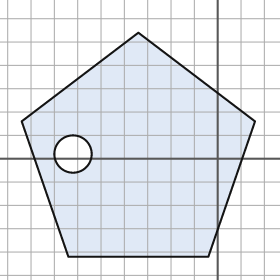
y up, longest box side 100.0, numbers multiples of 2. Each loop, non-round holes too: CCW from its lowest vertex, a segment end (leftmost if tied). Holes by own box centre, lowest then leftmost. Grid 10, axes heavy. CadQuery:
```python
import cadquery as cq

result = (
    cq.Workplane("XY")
    .moveTo(-64.0, -42.0)
    .lineTo(-4.0, -42.0)
    .lineTo(16.0, 16.0)
    .lineTo(-34.0, 54.0)
    .lineTo(-84.0, 16.0)
    .close()
    .moveTo(-62.0, 2.0)
    .circle(8.0)
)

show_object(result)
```